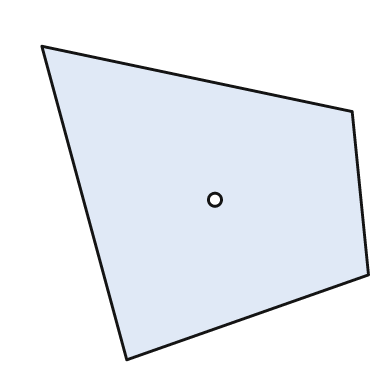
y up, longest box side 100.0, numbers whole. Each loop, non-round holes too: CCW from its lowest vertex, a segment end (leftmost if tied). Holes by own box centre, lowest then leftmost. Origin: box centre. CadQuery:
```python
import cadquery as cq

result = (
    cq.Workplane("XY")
    .moveTo(-24.0, -48.0)
    .lineTo(50.0, -22.0)
    .lineTo(45.0, 28.0)
    .lineTo(-50.0, 48.0)
    .close()
    .moveTo(3.0, 1.0)
    .circle(2.0)
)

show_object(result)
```